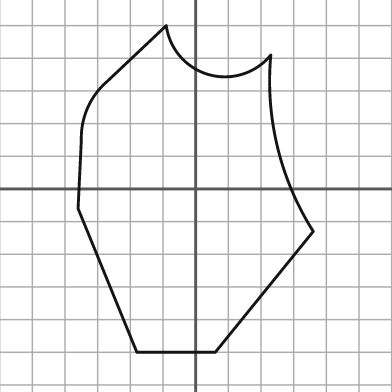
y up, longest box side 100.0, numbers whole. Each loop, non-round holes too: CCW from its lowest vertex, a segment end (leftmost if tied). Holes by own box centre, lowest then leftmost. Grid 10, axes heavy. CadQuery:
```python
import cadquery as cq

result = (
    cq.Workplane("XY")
    .moveTo(-18.0, -50.0)
    .lineTo(6.0, -50.0)
    .lineTo(36.0, -13.0)
    .threePointArc((25.0, 13.0), (23.0, 41.0))
    .threePointArc((4.0, 35.0), (-9.0, 50.0))
    .lineTo(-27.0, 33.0)
    .threePointArc((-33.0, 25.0), (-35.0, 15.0))
    .lineTo(-36.0, -6.0)
    .close()
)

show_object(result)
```